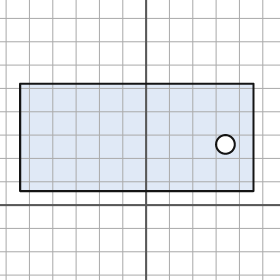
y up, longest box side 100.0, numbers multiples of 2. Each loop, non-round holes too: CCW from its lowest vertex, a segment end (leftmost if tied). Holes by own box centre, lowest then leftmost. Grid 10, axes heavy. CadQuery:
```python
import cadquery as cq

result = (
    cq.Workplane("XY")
    .moveTo(-54.0, 6.0)
    .lineTo(46.0, 6.0)
    .lineTo(46.0, 52.0)
    .lineTo(-54.0, 52.0)
    .close()
    .moveTo(34.0, 26.0)
    .circle(4.0)
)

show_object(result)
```